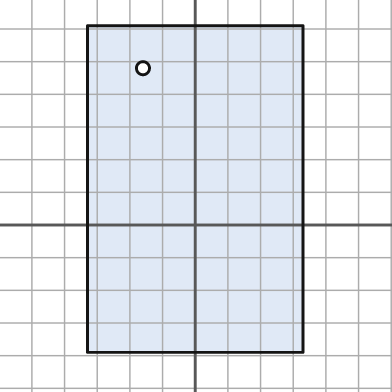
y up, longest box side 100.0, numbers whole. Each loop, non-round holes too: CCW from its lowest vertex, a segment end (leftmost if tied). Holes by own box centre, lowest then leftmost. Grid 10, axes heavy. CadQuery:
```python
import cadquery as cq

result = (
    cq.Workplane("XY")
    .moveTo(-33.0, -39.0)
    .lineTo(33.0, -39.0)
    .lineTo(33.0, 61.0)
    .lineTo(-33.0, 61.0)
    .close()
    .moveTo(-16.0, 48.0)
    .circle(2.0)
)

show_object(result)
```